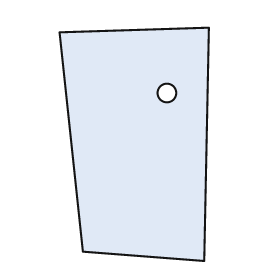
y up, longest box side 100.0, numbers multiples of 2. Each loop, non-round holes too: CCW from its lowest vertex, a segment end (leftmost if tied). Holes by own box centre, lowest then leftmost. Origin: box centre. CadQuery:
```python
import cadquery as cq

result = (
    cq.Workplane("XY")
    .moveTo(30.0, -50.0)
    .lineTo(32.0, 50.0)
    .lineTo(-32.0, 48.0)
    .lineTo(-22.0, -46.0)
    .close()
    .moveTo(14.0, 22.0)
    .circle(4.0)
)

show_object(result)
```